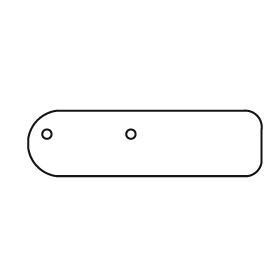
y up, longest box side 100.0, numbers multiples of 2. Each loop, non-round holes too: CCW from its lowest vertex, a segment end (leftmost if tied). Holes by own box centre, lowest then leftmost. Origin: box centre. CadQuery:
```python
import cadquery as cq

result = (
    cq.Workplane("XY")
    .moveTo(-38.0, -14.0)
    .lineTo(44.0, -14.0)
    .threePointArc((48.0, -12.0), (50.0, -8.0))
    .lineTo(50.0, 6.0)
    .threePointArc((48.0, 12.0), (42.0, 14.0))
    .lineTo(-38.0, 14.0)
    .threePointArc((-46.0, 10.0), (-50.0, 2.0))
    .lineTo(-50.0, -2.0)
    .threePointArc((-46.0, -10.0), (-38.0, -14.0))
    .close()
    .moveTo(-42.0, 4.0)
    .circle(2.0)
    .moveTo(-6.0, 4.0)
    .circle(2.0)
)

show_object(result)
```